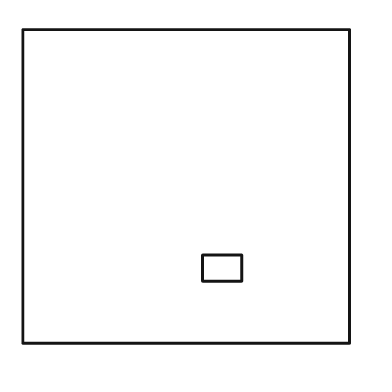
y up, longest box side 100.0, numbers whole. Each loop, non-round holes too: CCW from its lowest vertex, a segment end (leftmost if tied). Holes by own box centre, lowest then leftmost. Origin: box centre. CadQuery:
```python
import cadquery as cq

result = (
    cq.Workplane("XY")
    .moveTo(-50.0, -48.0)
    .lineTo(50.0, -48.0)
    .lineTo(50.0, 48.0)
    .lineTo(-50.0, 48.0)
    .close()
    .moveTo(5.0, -29.0)
    .lineTo(17.0, -29.0)
    .lineTo(17.0, -21.0)
    .lineTo(5.0, -21.0)
    .close()
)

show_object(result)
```